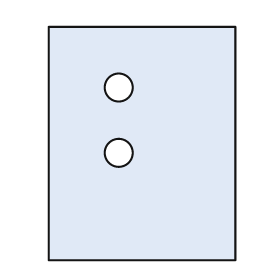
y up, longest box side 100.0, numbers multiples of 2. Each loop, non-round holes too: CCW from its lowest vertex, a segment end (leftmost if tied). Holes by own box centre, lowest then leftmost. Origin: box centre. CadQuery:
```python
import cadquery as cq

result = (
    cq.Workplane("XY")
    .moveTo(-40.0, -50.0)
    .lineTo(40.0, -50.0)
    .lineTo(40.0, 50.0)
    .lineTo(-40.0, 50.0)
    .close()
    .moveTo(-10.0, -4.0)
    .circle(6.0)
    .moveTo(-10.0, 24.0)
    .circle(6.0)
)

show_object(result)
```